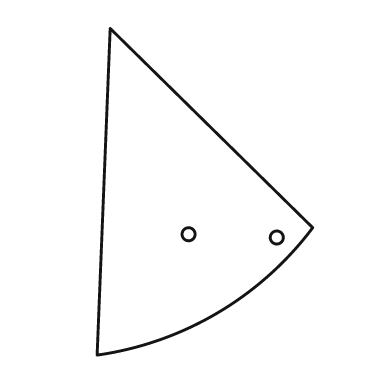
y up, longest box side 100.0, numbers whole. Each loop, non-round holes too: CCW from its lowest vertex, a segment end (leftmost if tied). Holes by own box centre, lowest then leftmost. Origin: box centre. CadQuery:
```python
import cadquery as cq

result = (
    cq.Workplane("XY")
    .moveTo(-33.0, -50.0)
    .threePointArc((4.0, -37.0), (33.0, -11.0))
    .lineTo(-29.0, 50.0)
    .close()
    .moveTo(22.0, -14.0)
    .circle(2.0)
    .moveTo(-5.0, -13.0)
    .circle(2.0)
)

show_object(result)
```